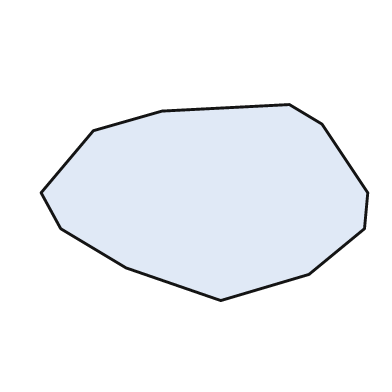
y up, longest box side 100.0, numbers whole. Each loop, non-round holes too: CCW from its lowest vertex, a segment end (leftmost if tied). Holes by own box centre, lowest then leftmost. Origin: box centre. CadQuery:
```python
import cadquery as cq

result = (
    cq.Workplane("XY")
    .moveTo(5.0, -30.0)
    .lineTo(32.0, -22.0)
    .lineTo(49.0, -8.0)
    .lineTo(50.0, 3.0)
    .lineTo(36.0, 24.0)
    .lineTo(26.0, 30.0)
    .lineTo(-13.0, 28.0)
    .lineTo(-34.0, 22.0)
    .lineTo(-50.0, 3.0)
    .lineTo(-44.0, -8.0)
    .lineTo(-24.0, -20.0)
    .close()
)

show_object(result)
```